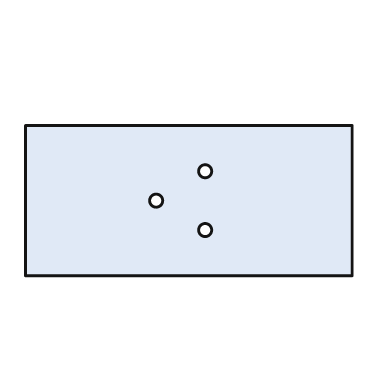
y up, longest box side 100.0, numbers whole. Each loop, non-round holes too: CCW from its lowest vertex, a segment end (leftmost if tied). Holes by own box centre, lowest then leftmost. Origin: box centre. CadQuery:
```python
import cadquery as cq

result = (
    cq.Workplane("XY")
    .moveTo(-50.0, -23.0)
    .lineTo(50.0, -23.0)
    .lineTo(50.0, 23.0)
    .lineTo(-50.0, 23.0)
    .close()
    .moveTo(5.0, -9.0)
    .circle(2.0)
    .moveTo(-10.0, 0.0)
    .circle(2.0)
    .moveTo(5.0, 9.0)
    .circle(2.0)
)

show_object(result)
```